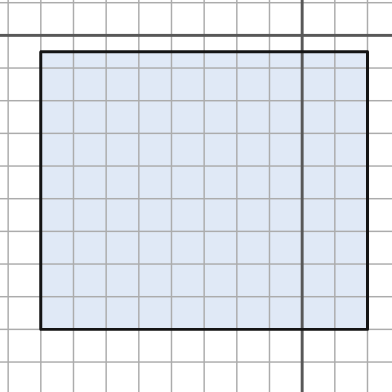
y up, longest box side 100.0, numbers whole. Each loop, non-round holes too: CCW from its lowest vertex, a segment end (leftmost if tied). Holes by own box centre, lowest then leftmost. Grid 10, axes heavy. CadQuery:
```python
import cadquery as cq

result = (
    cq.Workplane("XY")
    .moveTo(-80.0, -90.0)
    .lineTo(20.0, -90.0)
    .lineTo(20.0, -5.0)
    .lineTo(-80.0, -5.0)
    .close()
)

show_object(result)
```